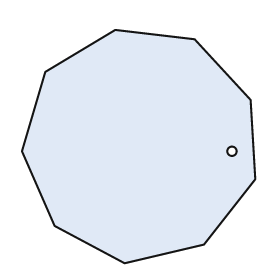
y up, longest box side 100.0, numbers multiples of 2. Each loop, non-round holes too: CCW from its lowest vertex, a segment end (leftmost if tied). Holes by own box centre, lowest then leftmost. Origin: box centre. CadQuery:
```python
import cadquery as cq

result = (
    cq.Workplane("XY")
    .moveTo(-6.0, -50.0)
    .lineTo(28.0, -42.0)
    .lineTo(50.0, -14.0)
    .lineTo(48.0, 20.0)
    .lineTo(24.0, 46.0)
    .lineTo(-10.0, 50.0)
    .lineTo(-40.0, 32.0)
    .lineTo(-50.0, -2.0)
    .lineTo(-36.0, -34.0)
    .close()
    .moveTo(40.0, -2.0)
    .circle(2.0)
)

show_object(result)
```